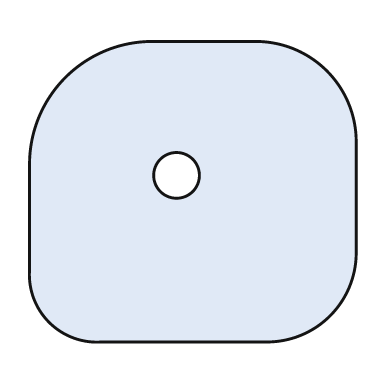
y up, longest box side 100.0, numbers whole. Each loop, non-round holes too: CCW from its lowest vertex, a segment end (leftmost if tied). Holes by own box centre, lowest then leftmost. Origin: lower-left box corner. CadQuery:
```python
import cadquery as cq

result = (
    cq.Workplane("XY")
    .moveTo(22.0, 0.0)
    .lineTo(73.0, 0.0)
    .threePointArc((92.0, 8.0), (100.0, 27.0))
    .lineTo(100.0, 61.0)
    .threePointArc((91.0, 83.0), (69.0, 92.0))
    .lineTo(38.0, 92.0)
    .threePointArc((11.0, 81.0), (0.0, 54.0))
    .lineTo(0.0, 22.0)
    .threePointArc((6.0, 6.0), (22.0, 0.0))
    .close()
    .moveTo(45.0, 51.0)
    .circle(7.0)
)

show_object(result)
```